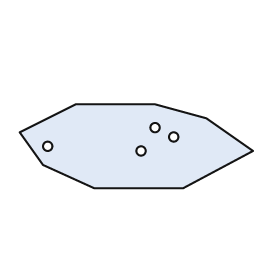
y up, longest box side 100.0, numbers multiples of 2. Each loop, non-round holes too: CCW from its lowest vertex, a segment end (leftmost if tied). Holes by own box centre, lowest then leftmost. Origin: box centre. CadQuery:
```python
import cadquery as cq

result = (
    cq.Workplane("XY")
    .moveTo(-18.0, -18.0)
    .lineTo(20.0, -18.0)
    .lineTo(50.0, -2.0)
    .lineTo(30.0, 12.0)
    .lineTo(8.0, 18.0)
    .lineTo(-26.0, 18.0)
    .lineTo(-50.0, 6.0)
    .lineTo(-40.0, -8.0)
    .close()
    .moveTo(2.0, -2.0)
    .circle(2.0)
    .moveTo(-38.0, 0.0)
    .circle(2.0)
    .moveTo(16.0, 4.0)
    .circle(2.0)
    .moveTo(8.0, 8.0)
    .circle(2.0)
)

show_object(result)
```